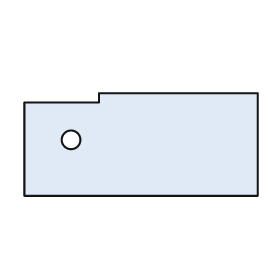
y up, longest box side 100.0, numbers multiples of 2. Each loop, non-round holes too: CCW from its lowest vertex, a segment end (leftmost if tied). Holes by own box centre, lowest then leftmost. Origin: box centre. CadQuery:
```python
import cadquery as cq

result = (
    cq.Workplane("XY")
    .moveTo(-50.0, -22.0)
    .lineTo(50.0, -22.0)
    .lineTo(50.0, 22.0)
    .lineTo(-18.0, 22.0)
    .lineTo(-18.0, 18.0)
    .lineTo(-50.0, 18.0)
    .close()
    .moveTo(-30.0, 2.0)
    .circle(4.0)
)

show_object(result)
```